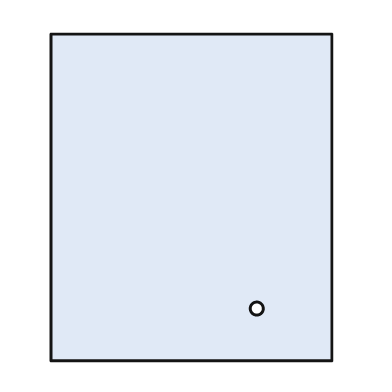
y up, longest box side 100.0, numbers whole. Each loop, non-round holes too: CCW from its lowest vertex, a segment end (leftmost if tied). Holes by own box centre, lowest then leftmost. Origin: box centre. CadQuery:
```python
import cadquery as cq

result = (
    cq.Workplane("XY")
    .moveTo(-43.0, -50.0)
    .lineTo(43.0, -50.0)
    .lineTo(43.0, 50.0)
    .lineTo(-43.0, 50.0)
    .close()
    .moveTo(20.0, -34.0)
    .circle(2.0)
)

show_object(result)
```